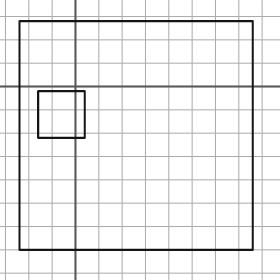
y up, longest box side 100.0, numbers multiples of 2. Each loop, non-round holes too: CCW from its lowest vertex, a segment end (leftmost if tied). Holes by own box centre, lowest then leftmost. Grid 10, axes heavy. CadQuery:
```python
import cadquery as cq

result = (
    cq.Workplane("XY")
    .moveTo(-24.0, -70.0)
    .lineTo(76.0, -70.0)
    .lineTo(76.0, 28.0)
    .lineTo(-24.0, 28.0)
    .close()
    .moveTo(-16.0, -22.0)
    .lineTo(4.0, -22.0)
    .lineTo(4.0, -2.0)
    .lineTo(-16.0, -2.0)
    .close()
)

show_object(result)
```